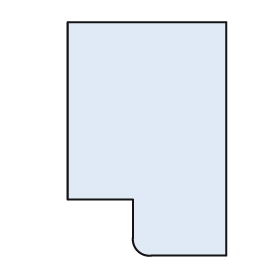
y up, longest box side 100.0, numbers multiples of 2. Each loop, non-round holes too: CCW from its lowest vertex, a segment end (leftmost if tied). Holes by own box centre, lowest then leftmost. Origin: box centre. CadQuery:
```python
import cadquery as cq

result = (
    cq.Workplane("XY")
    .moveTo(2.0, -50.0)
    .lineTo(34.0, -50.0)
    .lineTo(34.0, 50.0)
    .lineTo(-34.0, 50.0)
    .lineTo(-34.0, -26.0)
    .lineTo(-6.0, -26.0)
    .lineTo(-6.0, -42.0)
    .threePointArc((-4.0, -48.0), (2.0, -50.0))
    .close()
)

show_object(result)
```